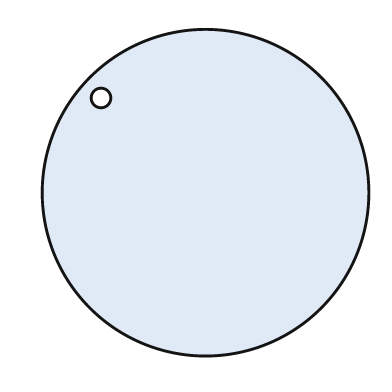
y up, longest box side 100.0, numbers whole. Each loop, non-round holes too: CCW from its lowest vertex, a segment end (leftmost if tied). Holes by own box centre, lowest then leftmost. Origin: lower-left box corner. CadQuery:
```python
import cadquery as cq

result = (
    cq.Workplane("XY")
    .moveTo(50.0, 50.0)
    .circle(50.0)
    .moveTo(18.0, 79.0)
    .circle(3.0)
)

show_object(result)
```